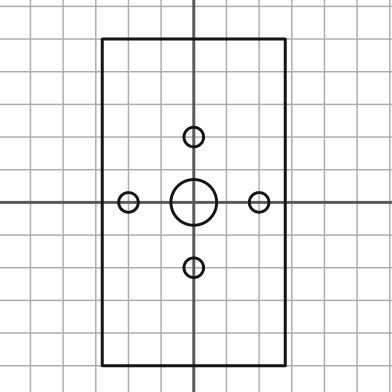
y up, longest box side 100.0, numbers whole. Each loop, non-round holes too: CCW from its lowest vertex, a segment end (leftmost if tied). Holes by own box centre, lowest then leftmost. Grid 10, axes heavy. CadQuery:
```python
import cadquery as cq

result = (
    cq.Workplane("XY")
    .moveTo(-28.0, -50.0)
    .lineTo(28.0, -50.0)
    .lineTo(28.0, 50.0)
    .lineTo(-28.0, 50.0)
    .close()
    .moveTo(0.0, -20.0)
    .circle(3.0)
    .moveTo(-20.0, 0.0)
    .circle(3.0)
    .moveTo(0.0, 0.0)
    .circle(7.0)
    .moveTo(20.0, 0.0)
    .circle(3.0)
    .moveTo(0.0, 20.0)
    .circle(3.0)
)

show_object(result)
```